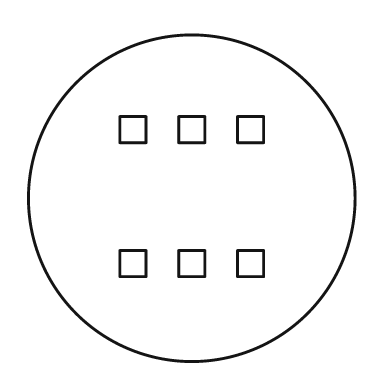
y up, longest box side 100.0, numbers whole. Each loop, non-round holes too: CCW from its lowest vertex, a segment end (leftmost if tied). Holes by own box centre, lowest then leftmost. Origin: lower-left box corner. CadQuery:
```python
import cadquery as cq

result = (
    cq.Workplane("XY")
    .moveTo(50.0, 50.0)
    .circle(50.0)
    .moveTo(28.0, 26.0)
    .lineTo(36.0, 26.0)
    .lineTo(36.0, 34.0)
    .lineTo(28.0, 34.0)
    .close()
    .moveTo(46.0, 26.0)
    .lineTo(54.0, 26.0)
    .lineTo(54.0, 34.0)
    .lineTo(46.0, 34.0)
    .close()
    .moveTo(64.0, 26.0)
    .lineTo(72.0, 26.0)
    .lineTo(72.0, 34.0)
    .lineTo(64.0, 34.0)
    .close()
    .moveTo(28.0, 67.0)
    .lineTo(36.0, 67.0)
    .lineTo(36.0, 75.0)
    .lineTo(28.0, 75.0)
    .close()
    .moveTo(46.0, 67.0)
    .lineTo(54.0, 67.0)
    .lineTo(54.0, 75.0)
    .lineTo(46.0, 75.0)
    .close()
    .moveTo(64.0, 67.0)
    .lineTo(72.0, 67.0)
    .lineTo(72.0, 75.0)
    .lineTo(64.0, 75.0)
    .close()
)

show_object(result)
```